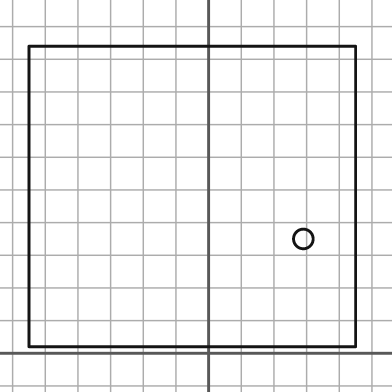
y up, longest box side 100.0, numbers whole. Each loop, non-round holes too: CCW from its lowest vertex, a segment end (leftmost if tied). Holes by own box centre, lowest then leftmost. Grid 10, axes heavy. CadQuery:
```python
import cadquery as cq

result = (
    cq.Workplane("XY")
    .moveTo(-55.0, 2.0)
    .lineTo(45.0, 2.0)
    .lineTo(45.0, 94.0)
    .lineTo(-55.0, 94.0)
    .close()
    .moveTo(29.0, 35.0)
    .circle(3.0)
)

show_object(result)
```